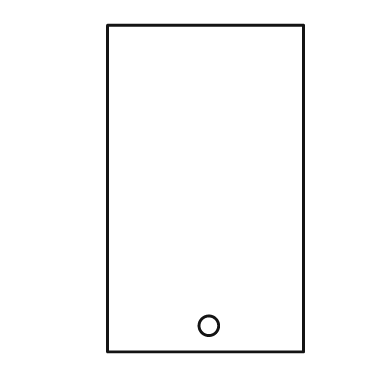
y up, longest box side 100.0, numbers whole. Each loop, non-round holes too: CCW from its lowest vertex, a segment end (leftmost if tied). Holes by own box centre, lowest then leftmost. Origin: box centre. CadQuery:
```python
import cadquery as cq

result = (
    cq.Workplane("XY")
    .moveTo(-30.0, -50.0)
    .lineTo(30.0, -50.0)
    .lineTo(30.0, 50.0)
    .lineTo(-30.0, 50.0)
    .close()
    .moveTo(1.0, -42.0)
    .circle(3.0)
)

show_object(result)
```